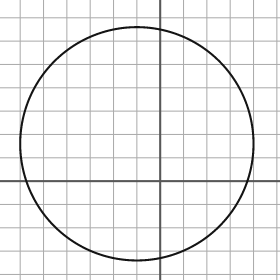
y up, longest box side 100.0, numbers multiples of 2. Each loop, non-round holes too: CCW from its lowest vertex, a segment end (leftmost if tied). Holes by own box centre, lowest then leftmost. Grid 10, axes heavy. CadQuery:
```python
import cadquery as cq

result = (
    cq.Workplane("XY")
    .moveTo(-10.0, 16.0)
    .circle(50.0)
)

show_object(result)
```